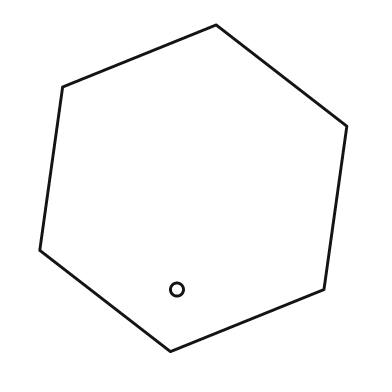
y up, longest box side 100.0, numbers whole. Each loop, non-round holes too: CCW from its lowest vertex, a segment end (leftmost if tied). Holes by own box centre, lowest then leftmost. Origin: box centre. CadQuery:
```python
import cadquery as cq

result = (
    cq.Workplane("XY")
    .moveTo(-7.0, -50.0)
    .lineTo(40.0, -31.0)
    .lineTo(47.0, 19.0)
    .lineTo(7.0, 50.0)
    .lineTo(-40.0, 31.0)
    .lineTo(-47.0, -19.0)
    .close()
    .moveTo(-5.0, -31.0)
    .circle(2.0)
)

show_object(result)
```